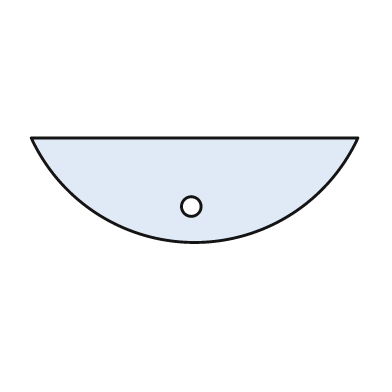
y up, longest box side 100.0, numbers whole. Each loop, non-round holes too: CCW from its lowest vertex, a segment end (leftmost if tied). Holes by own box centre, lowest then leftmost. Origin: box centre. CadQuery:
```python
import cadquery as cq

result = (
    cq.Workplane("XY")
    .moveTo(-50.0, 16.0)
    .threePointArc((0.0, -16.0), (50.0, 16.0))
    .close()
    .moveTo(-1.0, -5.0)
    .circle(3.0)
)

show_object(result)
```